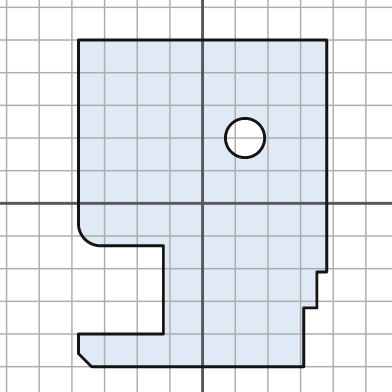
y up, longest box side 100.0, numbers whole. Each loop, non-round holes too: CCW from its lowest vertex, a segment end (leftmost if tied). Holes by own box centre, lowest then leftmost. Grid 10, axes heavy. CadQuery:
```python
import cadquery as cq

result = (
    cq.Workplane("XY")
    .moveTo(-34.0, -50.0)
    .lineTo(31.0, -50.0)
    .lineTo(31.0, -32.0)
    .lineTo(35.0, -32.0)
    .lineTo(35.0, -21.0)
    .lineTo(38.0, -21.0)
    .lineTo(38.0, 50.0)
    .lineTo(-38.0, 50.0)
    .lineTo(-38.0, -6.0)
    .threePointArc((-36.0, -11.0), (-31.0, -13.0))
    .lineTo(-12.0, -13.0)
    .lineTo(-12.0, -40.0)
    .lineTo(-38.0, -40.0)
    .lineTo(-38.0, -46.0)
    .close()
    .moveTo(13.0, 20.0)
    .circle(6.0)
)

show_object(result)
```